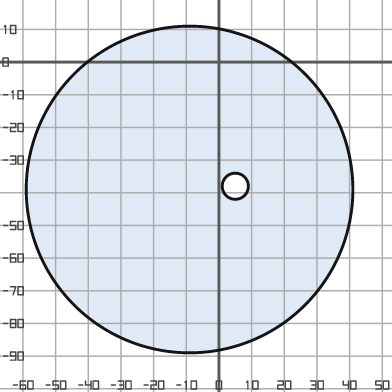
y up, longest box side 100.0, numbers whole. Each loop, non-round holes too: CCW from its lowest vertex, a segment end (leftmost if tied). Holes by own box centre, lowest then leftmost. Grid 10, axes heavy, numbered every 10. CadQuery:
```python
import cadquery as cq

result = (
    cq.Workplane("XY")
    .moveTo(-9.0, -39.0)
    .circle(50.0)
    .moveTo(5.0, -38.0)
    .circle(4.0)
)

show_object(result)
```